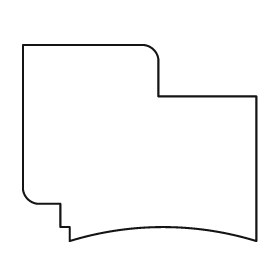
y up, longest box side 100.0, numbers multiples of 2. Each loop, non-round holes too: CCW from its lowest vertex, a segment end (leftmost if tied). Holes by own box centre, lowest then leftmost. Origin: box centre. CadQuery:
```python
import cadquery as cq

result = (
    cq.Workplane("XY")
    .moveTo(-30.0, -42.0)
    .threePointArc((10.0, -36.0), (50.0, -42.0))
    .lineTo(50.0, 20.0)
    .lineTo(8.0, 20.0)
    .lineTo(8.0, 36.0)
    .threePointArc((6.0, 40.0), (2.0, 42.0))
    .lineTo(-50.0, 42.0)
    .lineTo(-50.0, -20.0)
    .threePointArc((-48.0, -24.0), (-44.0, -26.0))
    .lineTo(-34.0, -26.0)
    .lineTo(-34.0, -36.0)
    .lineTo(-30.0, -36.0)
    .close()
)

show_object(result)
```